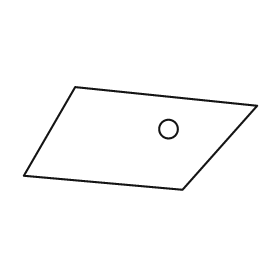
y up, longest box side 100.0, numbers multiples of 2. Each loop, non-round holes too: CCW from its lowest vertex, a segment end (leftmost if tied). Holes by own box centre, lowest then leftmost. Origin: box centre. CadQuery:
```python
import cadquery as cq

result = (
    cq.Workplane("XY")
    .moveTo(18.0, -22.0)
    .lineTo(50.0, 14.0)
    .lineTo(-28.0, 22.0)
    .lineTo(-50.0, -16.0)
    .close()
    .moveTo(12.0, 4.0)
    .circle(4.0)
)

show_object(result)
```